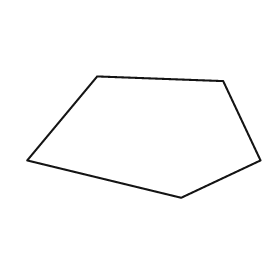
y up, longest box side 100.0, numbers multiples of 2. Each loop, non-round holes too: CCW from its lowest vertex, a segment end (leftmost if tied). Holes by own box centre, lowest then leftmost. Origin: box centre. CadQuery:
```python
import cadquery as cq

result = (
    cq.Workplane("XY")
    .moveTo(16.0, -26.0)
    .lineTo(50.0, -10.0)
    .lineTo(34.0, 24.0)
    .lineTo(-20.0, 26.0)
    .lineTo(-50.0, -10.0)
    .close()
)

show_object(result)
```